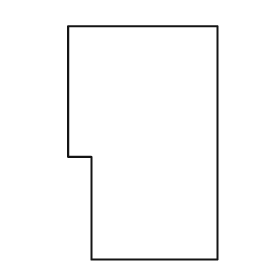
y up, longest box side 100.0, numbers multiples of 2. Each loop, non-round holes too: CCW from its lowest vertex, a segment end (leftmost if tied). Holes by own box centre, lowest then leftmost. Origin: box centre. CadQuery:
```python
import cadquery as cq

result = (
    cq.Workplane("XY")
    .moveTo(-22.0, -50.0)
    .lineTo(32.0, -50.0)
    .lineTo(32.0, 50.0)
    .lineTo(-32.0, 50.0)
    .lineTo(-32.0, -6.0)
    .lineTo(-22.0, -6.0)
    .close()
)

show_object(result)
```